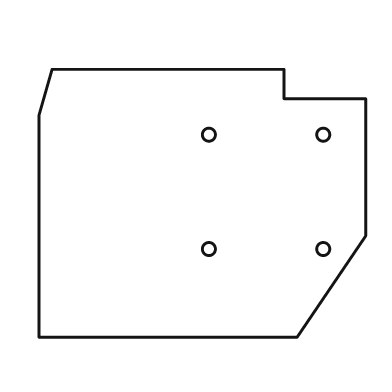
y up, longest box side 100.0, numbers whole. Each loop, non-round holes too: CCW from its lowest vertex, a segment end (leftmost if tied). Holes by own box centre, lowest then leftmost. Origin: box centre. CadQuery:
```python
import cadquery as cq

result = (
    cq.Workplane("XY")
    .moveTo(-50.0, -41.0)
    .lineTo(29.0, -41.0)
    .lineTo(50.0, -10.0)
    .lineTo(50.0, 32.0)
    .lineTo(25.0, 32.0)
    .lineTo(25.0, 41.0)
    .lineTo(-46.0, 41.0)
    .lineTo(-50.0, 27.0)
    .close()
    .moveTo(2.0, -14.0)
    .circle(2.0)
    .moveTo(37.0, -14.0)
    .circle(2.0)
    .moveTo(2.0, 21.0)
    .circle(2.0)
    .moveTo(37.0, 21.0)
    .circle(2.0)
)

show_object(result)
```